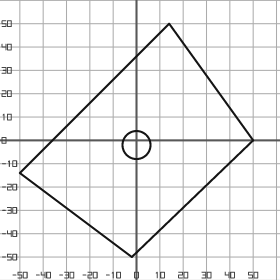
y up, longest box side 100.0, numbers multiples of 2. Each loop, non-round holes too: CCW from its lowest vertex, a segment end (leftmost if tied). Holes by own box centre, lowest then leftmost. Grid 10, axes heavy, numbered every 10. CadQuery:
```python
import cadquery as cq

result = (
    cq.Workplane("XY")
    .moveTo(-2.0, -50.0)
    .lineTo(50.0, 0.0)
    .lineTo(14.0, 50.0)
    .lineTo(-50.0, -14.0)
    .close()
    .moveTo(0.0, -2.0)
    .circle(6.0)
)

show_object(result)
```